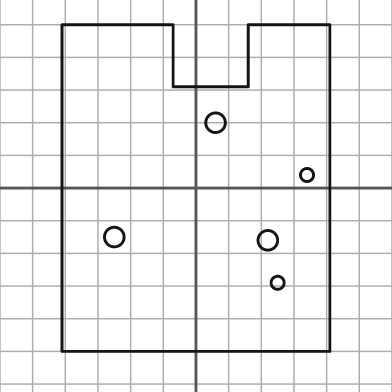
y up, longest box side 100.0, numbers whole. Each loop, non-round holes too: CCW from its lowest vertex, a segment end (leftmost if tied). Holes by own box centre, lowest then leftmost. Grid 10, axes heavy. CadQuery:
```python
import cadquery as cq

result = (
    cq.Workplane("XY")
    .moveTo(-41.0, -50.0)
    .lineTo(41.0, -50.0)
    .lineTo(41.0, 50.0)
    .lineTo(16.0, 50.0)
    .lineTo(16.0, 31.0)
    .lineTo(-7.0, 31.0)
    .lineTo(-7.0, 50.0)
    .lineTo(-41.0, 50.0)
    .close()
    .moveTo(25.0, -29.0)
    .circle(2.0)
    .moveTo(22.0, -16.0)
    .circle(3.0)
    .moveTo(-25.0, -15.0)
    .circle(3.0)
    .moveTo(34.0, 4.0)
    .circle(2.0)
    .moveTo(6.0, 20.0)
    .circle(3.0)
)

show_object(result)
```